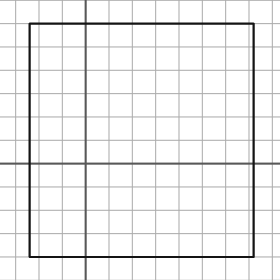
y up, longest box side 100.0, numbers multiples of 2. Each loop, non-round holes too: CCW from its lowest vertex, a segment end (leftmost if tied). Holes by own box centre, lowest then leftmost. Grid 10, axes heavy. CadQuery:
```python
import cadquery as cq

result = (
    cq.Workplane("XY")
    .moveTo(-24.0, -40.0)
    .lineTo(72.0, -40.0)
    .lineTo(72.0, 60.0)
    .lineTo(-24.0, 60.0)
    .close()
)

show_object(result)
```